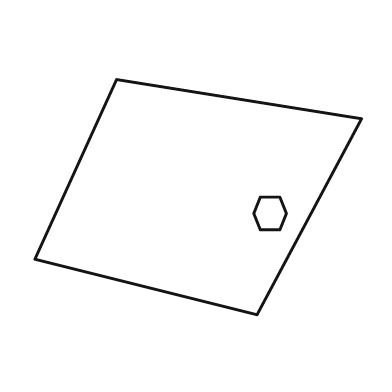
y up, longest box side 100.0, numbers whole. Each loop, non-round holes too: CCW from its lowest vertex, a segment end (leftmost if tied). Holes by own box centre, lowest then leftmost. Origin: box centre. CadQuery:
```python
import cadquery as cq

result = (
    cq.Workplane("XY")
    .moveTo(18.0, -36.0)
    .lineTo(50.0, 24.0)
    .lineTo(-25.0, 36.0)
    .lineTo(-50.0, -19.0)
    .close()
    .moveTo(19.0, -10.0)
    .lineTo(25.0, -10.0)
    .lineTo(27.0, -5.0)
    .lineTo(25.0, 0.0)
    .lineTo(19.0, 0.0)
    .lineTo(17.0, -5.0)
    .close()
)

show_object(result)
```